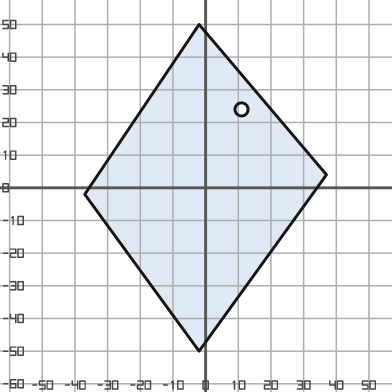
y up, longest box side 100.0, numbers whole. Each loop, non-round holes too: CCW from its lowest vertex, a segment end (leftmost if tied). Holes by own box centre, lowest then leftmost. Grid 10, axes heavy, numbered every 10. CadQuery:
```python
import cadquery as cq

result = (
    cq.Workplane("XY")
    .moveTo(-2.0, -50.0)
    .lineTo(37.0, 4.0)
    .lineTo(-2.0, 50.0)
    .lineTo(-37.0, -2.0)
    .close()
    .moveTo(11.0, 24.0)
    .circle(2.0)
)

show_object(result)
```